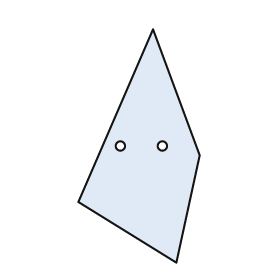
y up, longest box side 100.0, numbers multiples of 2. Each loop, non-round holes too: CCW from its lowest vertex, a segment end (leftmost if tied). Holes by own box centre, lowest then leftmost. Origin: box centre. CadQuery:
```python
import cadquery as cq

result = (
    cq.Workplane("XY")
    .moveTo(16.0, -50.0)
    .lineTo(26.0, -4.0)
    .lineTo(6.0, 50.0)
    .lineTo(-26.0, -24.0)
    .close()
    .moveTo(-8.0, 0.0)
    .circle(2.0)
    .moveTo(10.0, 0.0)
    .circle(2.0)
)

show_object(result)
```